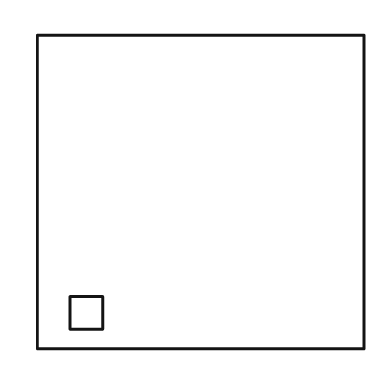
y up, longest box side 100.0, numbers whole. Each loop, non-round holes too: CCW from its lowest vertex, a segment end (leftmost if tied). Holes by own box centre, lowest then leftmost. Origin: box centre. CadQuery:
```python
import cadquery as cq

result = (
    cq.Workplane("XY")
    .moveTo(-50.0, -48.0)
    .lineTo(50.0, -48.0)
    .lineTo(50.0, 48.0)
    .lineTo(-50.0, 48.0)
    .close()
    .moveTo(-40.0, -42.0)
    .lineTo(-30.0, -42.0)
    .lineTo(-30.0, -32.0)
    .lineTo(-40.0, -32.0)
    .close()
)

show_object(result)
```